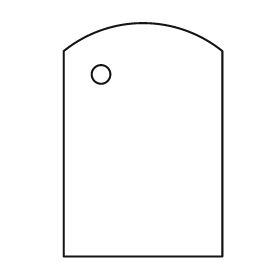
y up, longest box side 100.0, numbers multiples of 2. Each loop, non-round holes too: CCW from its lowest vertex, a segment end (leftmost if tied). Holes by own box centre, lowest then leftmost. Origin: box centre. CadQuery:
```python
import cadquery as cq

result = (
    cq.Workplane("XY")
    .moveTo(-34.0, -50.0)
    .lineTo(34.0, -50.0)
    .lineTo(34.0, 38.0)
    .threePointArc((0.0, 50.0), (-34.0, 38.0))
    .close()
    .moveTo(-18.0, 28.0)
    .circle(4.0)
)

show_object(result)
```